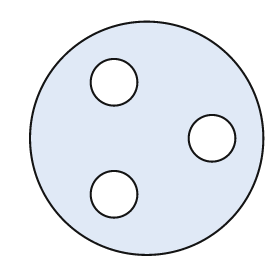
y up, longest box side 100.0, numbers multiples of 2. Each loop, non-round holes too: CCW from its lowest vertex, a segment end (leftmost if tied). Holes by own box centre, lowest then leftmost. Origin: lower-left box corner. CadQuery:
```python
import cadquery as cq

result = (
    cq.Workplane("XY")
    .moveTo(50.0, 50.0)
    .circle(50.0)
    .moveTo(36.0, 26.0)
    .circle(10.0)
    .moveTo(78.0, 50.0)
    .circle(10.0)
    .moveTo(36.0, 74.0)
    .circle(10.0)
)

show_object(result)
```